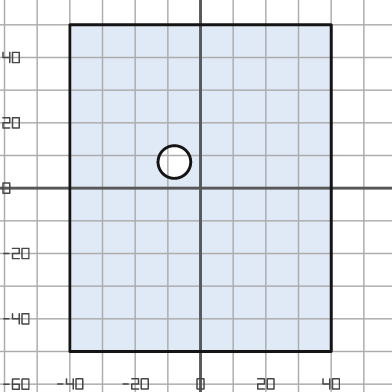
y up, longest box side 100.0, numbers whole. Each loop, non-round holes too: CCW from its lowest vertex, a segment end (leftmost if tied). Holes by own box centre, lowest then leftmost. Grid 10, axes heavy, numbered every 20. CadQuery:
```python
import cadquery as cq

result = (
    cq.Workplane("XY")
    .moveTo(-40.0, -50.0)
    .lineTo(40.0, -50.0)
    .lineTo(40.0, 50.0)
    .lineTo(-40.0, 50.0)
    .close()
    .moveTo(-8.0, 8.0)
    .circle(5.0)
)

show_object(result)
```